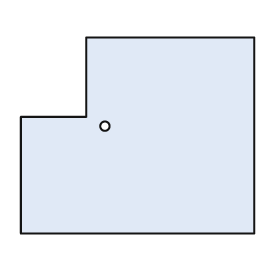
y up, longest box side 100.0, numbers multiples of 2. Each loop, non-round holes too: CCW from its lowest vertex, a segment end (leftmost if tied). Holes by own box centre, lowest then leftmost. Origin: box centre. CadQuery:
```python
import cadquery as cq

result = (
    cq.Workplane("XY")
    .moveTo(-50.0, -42.0)
    .lineTo(50.0, -42.0)
    .lineTo(50.0, 42.0)
    .lineTo(-22.0, 42.0)
    .lineTo(-22.0, 8.0)
    .lineTo(-50.0, 8.0)
    .close()
    .moveTo(-14.0, 4.0)
    .circle(2.0)
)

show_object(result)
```